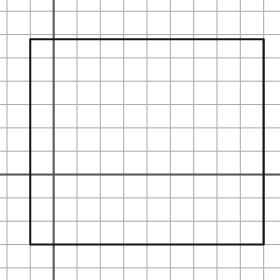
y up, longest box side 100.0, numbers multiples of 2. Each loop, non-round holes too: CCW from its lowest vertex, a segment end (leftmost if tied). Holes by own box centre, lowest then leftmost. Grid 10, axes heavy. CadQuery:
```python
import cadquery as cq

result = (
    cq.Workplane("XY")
    .moveTo(-10.0, -30.0)
    .lineTo(90.0, -30.0)
    .lineTo(90.0, 58.0)
    .lineTo(-10.0, 58.0)
    .close()
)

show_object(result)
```